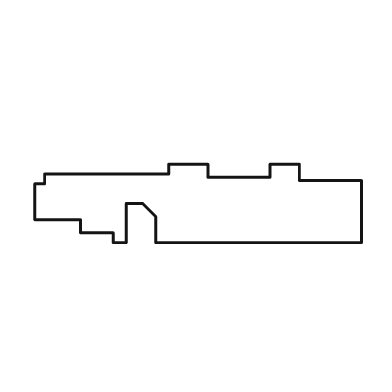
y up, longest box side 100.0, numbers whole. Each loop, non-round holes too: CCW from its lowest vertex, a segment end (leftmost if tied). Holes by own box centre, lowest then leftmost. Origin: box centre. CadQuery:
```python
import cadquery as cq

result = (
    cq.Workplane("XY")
    .moveTo(-26.0, -12.0)
    .lineTo(-22.0, -12.0)
    .lineTo(-22.0, 0.0)
    .lineTo(-17.0, 0.0)
    .lineTo(-13.0, -4.0)
    .lineTo(-13.0, -12.0)
    .lineTo(50.0, -12.0)
    .lineTo(50.0, 7.0)
    .lineTo(31.0, 7.0)
    .lineTo(31.0, 12.0)
    .lineTo(22.0, 12.0)
    .lineTo(22.0, 8.0)
    .lineTo(3.0, 8.0)
    .lineTo(3.0, 12.0)
    .lineTo(-9.0, 12.0)
    .lineTo(-9.0, 9.0)
    .lineTo(-47.0, 9.0)
    .lineTo(-47.0, 6.0)
    .lineTo(-50.0, 6.0)
    .lineTo(-50.0, -5.0)
    .lineTo(-36.0, -5.0)
    .lineTo(-36.0, -9.0)
    .lineTo(-26.0, -9.0)
    .close()
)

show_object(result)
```